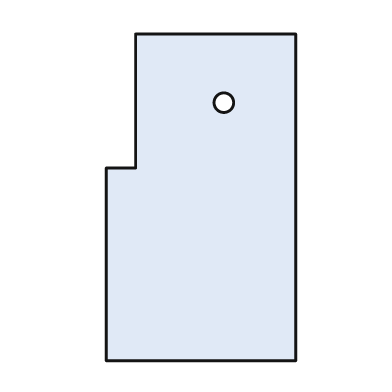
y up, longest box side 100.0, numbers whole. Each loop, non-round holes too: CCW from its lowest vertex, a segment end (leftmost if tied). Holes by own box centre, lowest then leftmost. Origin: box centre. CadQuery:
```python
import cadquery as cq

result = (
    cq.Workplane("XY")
    .moveTo(-29.0, -50.0)
    .lineTo(29.0, -50.0)
    .lineTo(29.0, 50.0)
    .lineTo(-20.0, 50.0)
    .lineTo(-20.0, 9.0)
    .lineTo(-29.0, 9.0)
    .close()
    .moveTo(7.0, 29.0)
    .circle(3.0)
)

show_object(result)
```